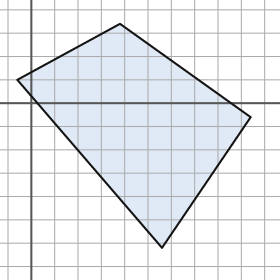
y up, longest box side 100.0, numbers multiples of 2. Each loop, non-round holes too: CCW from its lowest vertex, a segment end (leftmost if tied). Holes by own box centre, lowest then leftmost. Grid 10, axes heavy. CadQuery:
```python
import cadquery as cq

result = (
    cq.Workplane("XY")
    .moveTo(56.0, -62.0)
    .lineTo(94.0, -6.0)
    .lineTo(38.0, 34.0)
    .lineTo(-6.0, 10.0)
    .close()
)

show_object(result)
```